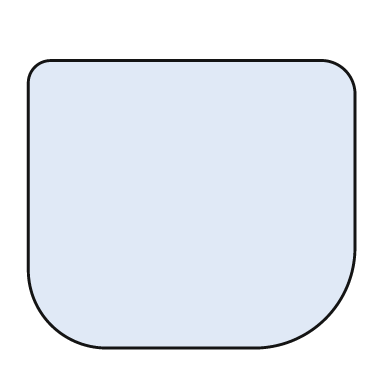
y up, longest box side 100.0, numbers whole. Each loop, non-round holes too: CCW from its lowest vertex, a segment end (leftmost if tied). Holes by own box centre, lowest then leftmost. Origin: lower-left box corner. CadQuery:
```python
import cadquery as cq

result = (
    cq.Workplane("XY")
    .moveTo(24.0, 0.0)
    .lineTo(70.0, 0.0)
    .threePointArc((91.0, 9.0), (100.0, 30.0))
    .lineTo(100.0, 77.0)
    .threePointArc((97.0, 85.0), (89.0, 88.0))
    .lineTo(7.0, 88.0)
    .threePointArc((2.0, 86.0), (0.0, 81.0))
    .lineTo(0.0, 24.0)
    .threePointArc((7.0, 7.0), (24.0, 0.0))
    .close()
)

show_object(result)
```